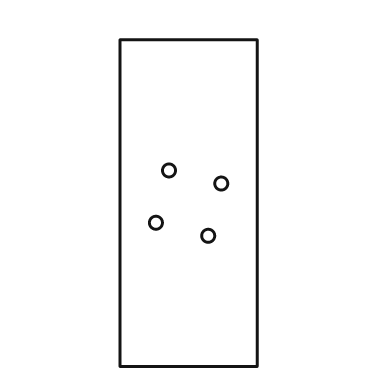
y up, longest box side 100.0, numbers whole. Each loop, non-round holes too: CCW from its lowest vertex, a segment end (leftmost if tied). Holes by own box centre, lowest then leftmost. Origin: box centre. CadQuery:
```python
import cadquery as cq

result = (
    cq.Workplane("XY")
    .moveTo(-21.0, -50.0)
    .lineTo(21.0, -50.0)
    .lineTo(21.0, 50.0)
    .lineTo(-21.0, 50.0)
    .close()
    .moveTo(6.0, -10.0)
    .circle(2.0)
    .moveTo(-10.0, -6.0)
    .circle(2.0)
    .moveTo(10.0, 6.0)
    .circle(2.0)
    .moveTo(-6.0, 10.0)
    .circle(2.0)
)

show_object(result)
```